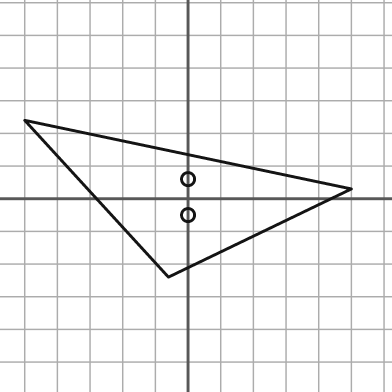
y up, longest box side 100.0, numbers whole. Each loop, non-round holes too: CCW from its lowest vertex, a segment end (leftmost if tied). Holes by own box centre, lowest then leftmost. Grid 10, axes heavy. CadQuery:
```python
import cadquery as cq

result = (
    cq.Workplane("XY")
    .moveTo(-6.0, -24.0)
    .lineTo(50.0, 3.0)
    .lineTo(-50.0, 24.0)
    .close()
    .moveTo(0.0, -5.0)
    .circle(2.0)
    .moveTo(0.0, 6.0)
    .circle(2.0)
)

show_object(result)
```